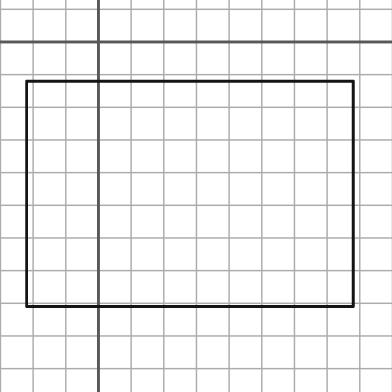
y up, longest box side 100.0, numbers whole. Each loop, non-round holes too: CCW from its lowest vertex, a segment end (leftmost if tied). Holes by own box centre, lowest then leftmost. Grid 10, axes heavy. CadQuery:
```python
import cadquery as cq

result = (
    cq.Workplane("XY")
    .moveTo(-22.0, -81.0)
    .lineTo(78.0, -81.0)
    .lineTo(78.0, -12.0)
    .lineTo(-22.0, -12.0)
    .close()
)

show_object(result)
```